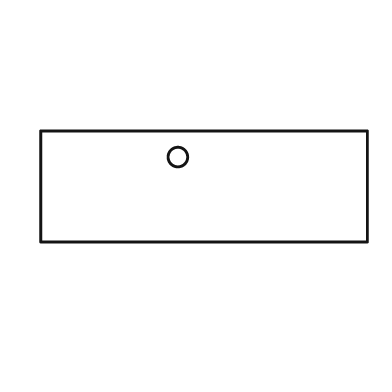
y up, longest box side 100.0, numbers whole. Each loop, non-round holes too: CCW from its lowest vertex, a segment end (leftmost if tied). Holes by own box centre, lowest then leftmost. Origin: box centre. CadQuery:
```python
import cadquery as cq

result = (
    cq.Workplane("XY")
    .moveTo(-50.0, -17.0)
    .lineTo(50.0, -17.0)
    .lineTo(50.0, 17.0)
    .lineTo(-50.0, 17.0)
    .close()
    .moveTo(-8.0, 9.0)
    .circle(3.0)
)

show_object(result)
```